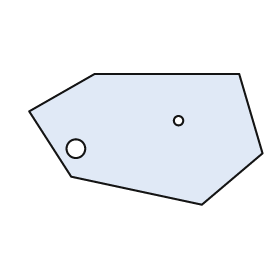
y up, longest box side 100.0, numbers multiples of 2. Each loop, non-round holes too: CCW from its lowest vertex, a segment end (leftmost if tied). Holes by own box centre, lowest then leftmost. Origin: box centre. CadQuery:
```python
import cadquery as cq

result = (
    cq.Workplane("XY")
    .moveTo(24.0, -28.0)
    .lineTo(50.0, -6.0)
    .lineTo(40.0, 28.0)
    .lineTo(-22.0, 28.0)
    .lineTo(-50.0, 12.0)
    .lineTo(-32.0, -16.0)
    .close()
    .moveTo(-30.0, -4.0)
    .circle(4.0)
    .moveTo(14.0, 8.0)
    .circle(2.0)
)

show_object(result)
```